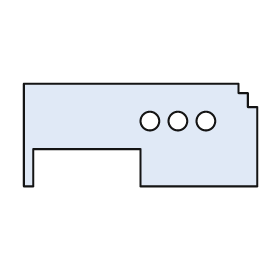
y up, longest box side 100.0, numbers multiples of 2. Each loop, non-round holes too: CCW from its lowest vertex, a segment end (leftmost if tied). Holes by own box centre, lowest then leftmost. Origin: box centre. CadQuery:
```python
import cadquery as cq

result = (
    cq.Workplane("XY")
    .moveTo(-50.0, -22.0)
    .lineTo(-46.0, -22.0)
    .lineTo(-46.0, -6.0)
    .lineTo(0.0, -6.0)
    .lineTo(0.0, -22.0)
    .lineTo(50.0, -22.0)
    .lineTo(50.0, 12.0)
    .lineTo(46.0, 12.0)
    .lineTo(46.0, 18.0)
    .lineTo(42.0, 18.0)
    .lineTo(42.0, 22.0)
    .lineTo(-50.0, 22.0)
    .close()
    .moveTo(4.0, 6.0)
    .circle(4.0)
    .moveTo(16.0, 6.0)
    .circle(4.0)
    .moveTo(28.0, 6.0)
    .circle(4.0)
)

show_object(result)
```